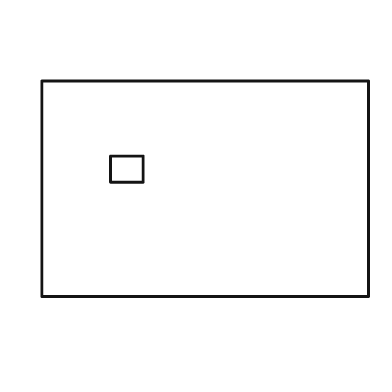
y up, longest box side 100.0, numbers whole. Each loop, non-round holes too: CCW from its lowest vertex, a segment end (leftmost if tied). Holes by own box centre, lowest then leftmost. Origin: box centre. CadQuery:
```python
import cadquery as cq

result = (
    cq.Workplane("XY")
    .moveTo(-50.0, -33.0)
    .lineTo(50.0, -33.0)
    .lineTo(50.0, 33.0)
    .lineTo(-50.0, 33.0)
    .close()
    .moveTo(-29.0, 2.0)
    .lineTo(-19.0, 2.0)
    .lineTo(-19.0, 10.0)
    .lineTo(-29.0, 10.0)
    .close()
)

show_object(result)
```